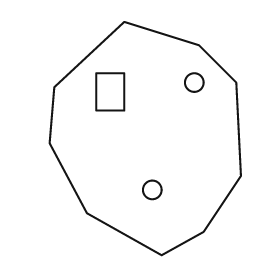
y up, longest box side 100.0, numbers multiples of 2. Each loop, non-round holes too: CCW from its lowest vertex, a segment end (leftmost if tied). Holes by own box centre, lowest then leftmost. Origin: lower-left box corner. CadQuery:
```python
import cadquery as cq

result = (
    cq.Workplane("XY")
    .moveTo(48.0, 0.0)
    .lineTo(66.0, 10.0)
    .lineTo(82.0, 34.0)
    .lineTo(80.0, 74.0)
    .lineTo(64.0, 90.0)
    .lineTo(32.0, 100.0)
    .lineTo(2.0, 72.0)
    .lineTo(0.0, 48.0)
    .lineTo(16.0, 18.0)
    .close()
    .moveTo(44.0, 28.0)
    .circle(4.0)
    .moveTo(20.0, 62.0)
    .lineTo(32.0, 62.0)
    .lineTo(32.0, 78.0)
    .lineTo(20.0, 78.0)
    .close()
    .moveTo(62.0, 74.0)
    .circle(4.0)
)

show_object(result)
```